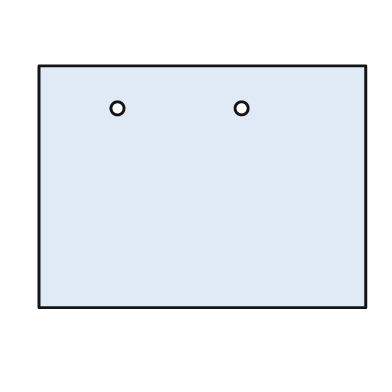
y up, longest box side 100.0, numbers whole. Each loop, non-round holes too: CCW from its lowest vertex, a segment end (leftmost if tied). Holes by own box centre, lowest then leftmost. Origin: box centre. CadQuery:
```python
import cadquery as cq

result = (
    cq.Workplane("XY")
    .moveTo(-50.0, -37.0)
    .lineTo(50.0, -37.0)
    .lineTo(50.0, 37.0)
    .lineTo(-50.0, 37.0)
    .close()
    .moveTo(-26.0, 24.0)
    .circle(2.0)
    .moveTo(12.0, 24.0)
    .circle(2.0)
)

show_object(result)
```